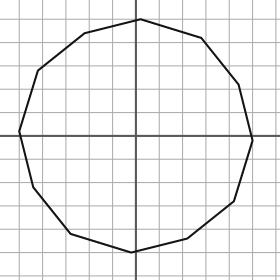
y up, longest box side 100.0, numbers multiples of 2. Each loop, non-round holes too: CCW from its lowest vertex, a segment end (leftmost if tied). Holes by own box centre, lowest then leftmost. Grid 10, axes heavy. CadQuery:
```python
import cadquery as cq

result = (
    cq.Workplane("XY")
    .moveTo(-2.0, -50.0)
    .lineTo(22.0, -44.0)
    .lineTo(42.0, -28.0)
    .lineTo(50.0, -2.0)
    .lineTo(44.0, 22.0)
    .lineTo(28.0, 42.0)
    .lineTo(2.0, 50.0)
    .lineTo(-22.0, 44.0)
    .lineTo(-42.0, 28.0)
    .lineTo(-50.0, 2.0)
    .lineTo(-44.0, -22.0)
    .lineTo(-28.0, -42.0)
    .close()
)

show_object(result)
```